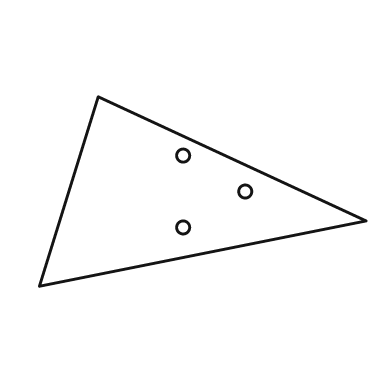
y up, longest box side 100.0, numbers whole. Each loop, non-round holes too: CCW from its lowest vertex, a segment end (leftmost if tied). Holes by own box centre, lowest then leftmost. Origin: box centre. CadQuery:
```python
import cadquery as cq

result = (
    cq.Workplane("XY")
    .moveTo(-50.0, -29.0)
    .lineTo(50.0, -9.0)
    .lineTo(-32.0, 29.0)
    .close()
    .moveTo(-6.0, -11.0)
    .circle(2.0)
    .moveTo(13.0, 0.0)
    .circle(2.0)
    .moveTo(-6.0, 11.0)
    .circle(2.0)
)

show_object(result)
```